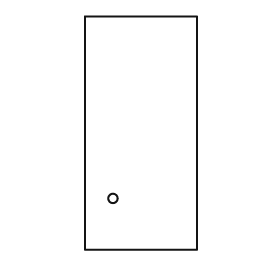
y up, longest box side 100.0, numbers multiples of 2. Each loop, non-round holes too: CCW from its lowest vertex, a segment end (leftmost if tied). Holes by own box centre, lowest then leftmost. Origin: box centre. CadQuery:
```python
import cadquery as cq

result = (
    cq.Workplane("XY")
    .moveTo(-24.0, -50.0)
    .lineTo(24.0, -50.0)
    .lineTo(24.0, 50.0)
    .lineTo(-24.0, 50.0)
    .close()
    .moveTo(-12.0, -28.0)
    .circle(2.0)
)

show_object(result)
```